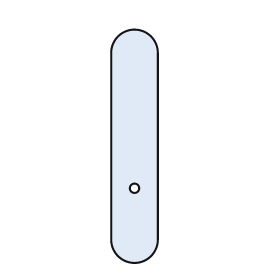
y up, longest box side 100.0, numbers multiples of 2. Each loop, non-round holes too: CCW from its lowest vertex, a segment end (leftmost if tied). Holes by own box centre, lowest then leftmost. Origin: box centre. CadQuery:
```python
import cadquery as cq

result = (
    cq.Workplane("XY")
    .moveTo(-10.0, -40.0)
    .threePointArc((0.0, -50.0), (10.0, -40.0))
    .lineTo(10.0, 40.0)
    .threePointArc((0.0, 50.0), (-10.0, 40.0))
    .close()
    .moveTo(0.0, -18.0)
    .circle(2.0)
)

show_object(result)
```